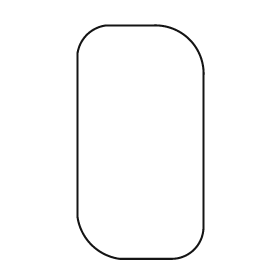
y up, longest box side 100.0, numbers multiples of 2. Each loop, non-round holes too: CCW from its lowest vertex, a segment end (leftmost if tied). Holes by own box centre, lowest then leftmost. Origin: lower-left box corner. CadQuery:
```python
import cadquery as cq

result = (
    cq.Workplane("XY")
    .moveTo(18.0, 0.0)
    .lineTo(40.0, 0.0)
    .threePointArc((50.0, 4.0), (54.0, 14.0))
    .lineTo(54.0, 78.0)
    .threePointArc((48.0, 94.0), (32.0, 100.0))
    .lineTo(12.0, 100.0)
    .threePointArc((4.0, 96.0), (0.0, 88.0))
    .lineTo(0.0, 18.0)
    .threePointArc((6.0, 6.0), (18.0, 0.0))
    .close()
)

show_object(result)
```